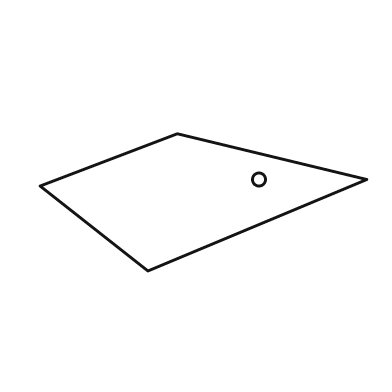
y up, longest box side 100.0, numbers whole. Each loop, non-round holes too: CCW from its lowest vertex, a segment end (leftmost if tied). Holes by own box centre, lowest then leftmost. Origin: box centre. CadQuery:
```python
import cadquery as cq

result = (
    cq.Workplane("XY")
    .moveTo(-17.0, -21.0)
    .lineTo(50.0, 7.0)
    .lineTo(-8.0, 21.0)
    .lineTo(-50.0, 5.0)
    .close()
    .moveTo(17.0, 7.0)
    .circle(2.0)
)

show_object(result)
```